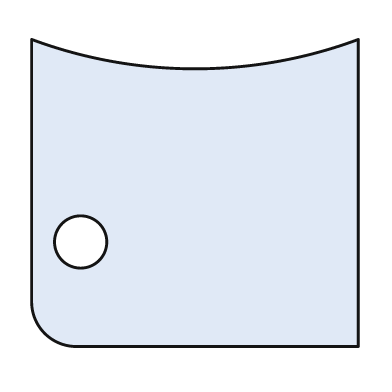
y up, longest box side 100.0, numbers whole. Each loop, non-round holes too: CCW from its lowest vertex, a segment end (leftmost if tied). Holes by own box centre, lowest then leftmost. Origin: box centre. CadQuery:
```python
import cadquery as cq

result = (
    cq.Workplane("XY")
    .moveTo(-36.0, -47.0)
    .lineTo(50.0, -47.0)
    .lineTo(50.0, 47.0)
    .threePointArc((0.0, 38.0), (-50.0, 47.0))
    .lineTo(-50.0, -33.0)
    .threePointArc((-46.0, -43.0), (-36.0, -47.0))
    .close()
    .moveTo(-35.0, -15.0)
    .circle(8.0)
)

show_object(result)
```